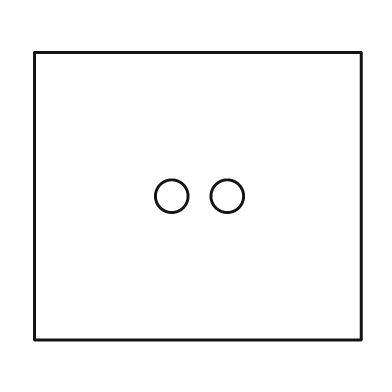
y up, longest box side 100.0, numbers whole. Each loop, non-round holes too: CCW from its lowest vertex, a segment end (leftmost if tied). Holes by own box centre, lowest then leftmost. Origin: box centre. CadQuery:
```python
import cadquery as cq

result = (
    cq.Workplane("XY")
    .moveTo(-50.0, -44.0)
    .lineTo(50.0, -44.0)
    .lineTo(50.0, 44.0)
    .lineTo(-50.0, 44.0)
    .close()
    .moveTo(-8.0, 0.0)
    .circle(5.0)
    .moveTo(9.0, 0.0)
    .circle(5.0)
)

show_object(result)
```